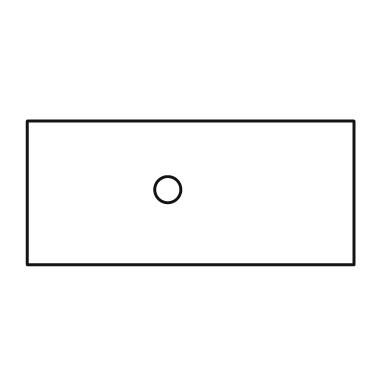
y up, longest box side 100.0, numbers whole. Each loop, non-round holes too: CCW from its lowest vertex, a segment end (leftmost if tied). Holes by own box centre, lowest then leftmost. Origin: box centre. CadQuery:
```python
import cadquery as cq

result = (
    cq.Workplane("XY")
    .moveTo(-50.0, -22.0)
    .lineTo(50.0, -22.0)
    .lineTo(50.0, 22.0)
    .lineTo(-50.0, 22.0)
    .close()
    .moveTo(-7.0, 1.0)
    .circle(4.0)
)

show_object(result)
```